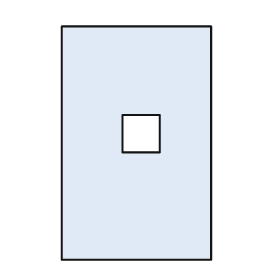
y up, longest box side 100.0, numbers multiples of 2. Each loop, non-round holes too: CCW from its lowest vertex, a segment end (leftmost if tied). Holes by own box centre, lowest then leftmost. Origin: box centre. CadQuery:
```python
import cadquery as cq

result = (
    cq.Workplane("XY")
    .moveTo(-32.0, -50.0)
    .lineTo(32.0, -50.0)
    .lineTo(32.0, 50.0)
    .lineTo(-32.0, 50.0)
    .close()
    .moveTo(-6.0, -4.0)
    .lineTo(10.0, -4.0)
    .lineTo(10.0, 12.0)
    .lineTo(-6.0, 12.0)
    .close()
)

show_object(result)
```